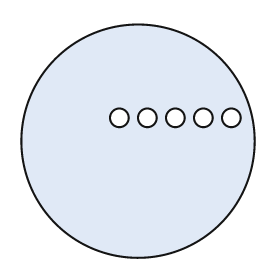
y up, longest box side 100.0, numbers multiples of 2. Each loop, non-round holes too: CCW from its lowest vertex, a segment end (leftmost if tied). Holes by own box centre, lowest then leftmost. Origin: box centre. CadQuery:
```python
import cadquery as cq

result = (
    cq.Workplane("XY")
    .moveTo(0.0, 0.0)
    .circle(50.0)
    .moveTo(-8.0, 10.0)
    .circle(4.0)
    .moveTo(4.0, 10.0)
    .circle(4.0)
    .moveTo(16.0, 10.0)
    .circle(4.0)
    .moveTo(28.0, 10.0)
    .circle(4.0)
    .moveTo(40.0, 10.0)
    .circle(4.0)
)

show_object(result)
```